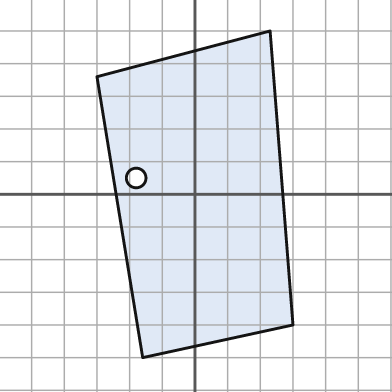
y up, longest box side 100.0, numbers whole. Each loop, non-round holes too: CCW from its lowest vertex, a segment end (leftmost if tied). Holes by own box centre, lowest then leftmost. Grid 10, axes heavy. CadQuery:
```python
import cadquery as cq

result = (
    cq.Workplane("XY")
    .moveTo(-16.0, -50.0)
    .lineTo(30.0, -40.0)
    .lineTo(23.0, 50.0)
    .lineTo(-30.0, 36.0)
    .close()
    .moveTo(-18.0, 5.0)
    .circle(3.0)
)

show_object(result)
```